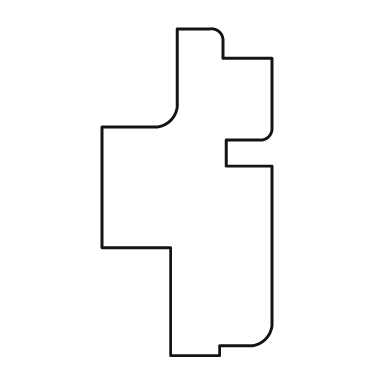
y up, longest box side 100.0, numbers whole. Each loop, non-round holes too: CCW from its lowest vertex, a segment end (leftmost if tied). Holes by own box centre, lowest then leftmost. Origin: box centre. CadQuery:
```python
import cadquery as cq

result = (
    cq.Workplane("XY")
    .moveTo(-5.0, -50.0)
    .lineTo(10.0, -50.0)
    .lineTo(10.0, -47.0)
    .lineTo(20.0, -47.0)
    .threePointArc((24.0, -45.0), (26.0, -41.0))
    .lineTo(26.0, 8.0)
    .lineTo(12.0, 8.0)
    .lineTo(12.0, 16.0)
    .lineTo(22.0, 16.0)
    .threePointArc((25.0, 17.0), (26.0, 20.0))
    .lineTo(26.0, 41.0)
    .lineTo(11.0, 41.0)
    .lineTo(11.0, 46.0)
    .threePointArc((10.0, 49.0), (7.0, 50.0))
    .lineTo(-3.0, 50.0)
    .lineTo(-3.0, 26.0)
    .threePointArc((-5.0, 22.0), (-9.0, 20.0))
    .lineTo(-26.0, 20.0)
    .lineTo(-26.0, -17.0)
    .lineTo(-5.0, -17.0)
    .close()
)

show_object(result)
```